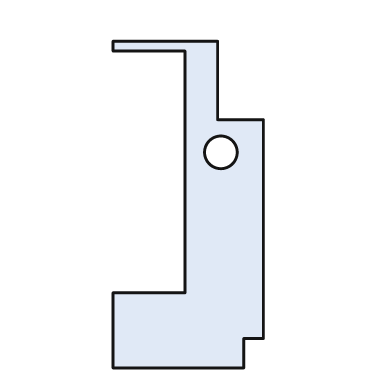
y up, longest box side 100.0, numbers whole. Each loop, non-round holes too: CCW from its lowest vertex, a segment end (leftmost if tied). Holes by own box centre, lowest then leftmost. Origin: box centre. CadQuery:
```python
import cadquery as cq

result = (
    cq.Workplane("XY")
    .moveTo(-23.0, -50.0)
    .lineTo(17.0, -50.0)
    .lineTo(17.0, -41.0)
    .lineTo(23.0, -41.0)
    .lineTo(23.0, 26.0)
    .lineTo(9.0, 26.0)
    .lineTo(9.0, 50.0)
    .lineTo(-23.0, 50.0)
    .lineTo(-23.0, 47.0)
    .lineTo(-1.0, 47.0)
    .lineTo(-1.0, -27.0)
    .lineTo(-23.0, -27.0)
    .close()
    .moveTo(10.0, 16.0)
    .circle(5.0)
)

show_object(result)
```